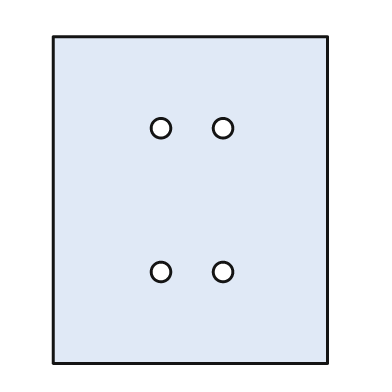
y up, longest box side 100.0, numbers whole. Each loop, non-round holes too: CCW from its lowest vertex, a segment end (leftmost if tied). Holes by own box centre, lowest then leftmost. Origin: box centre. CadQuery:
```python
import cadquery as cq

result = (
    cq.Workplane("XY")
    .moveTo(-42.0, -50.0)
    .lineTo(42.0, -50.0)
    .lineTo(42.0, 50.0)
    .lineTo(-42.0, 50.0)
    .close()
    .moveTo(-9.0, -22.0)
    .circle(3.0)
    .moveTo(10.0, -22.0)
    .circle(3.0)
    .moveTo(-9.0, 22.0)
    .circle(3.0)
    .moveTo(10.0, 22.0)
    .circle(3.0)
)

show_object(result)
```